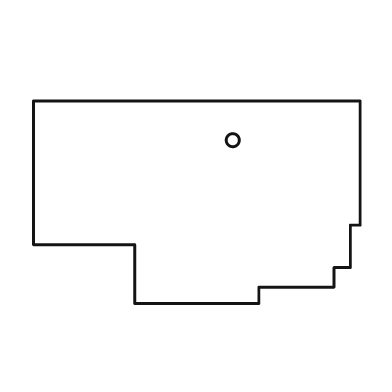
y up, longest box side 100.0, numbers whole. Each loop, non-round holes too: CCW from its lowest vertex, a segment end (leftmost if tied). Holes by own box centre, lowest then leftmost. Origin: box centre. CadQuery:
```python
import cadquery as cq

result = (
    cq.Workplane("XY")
    .moveTo(-19.0, -31.0)
    .lineTo(19.0, -31.0)
    .lineTo(19.0, -26.0)
    .lineTo(42.0, -26.0)
    .lineTo(42.0, -20.0)
    .lineTo(47.0, -20.0)
    .lineTo(47.0, -7.0)
    .lineTo(50.0, -7.0)
    .lineTo(50.0, 31.0)
    .lineTo(-50.0, 31.0)
    .lineTo(-50.0, -13.0)
    .lineTo(-19.0, -13.0)
    .close()
    .moveTo(11.0, 19.0)
    .circle(2.0)
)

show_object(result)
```